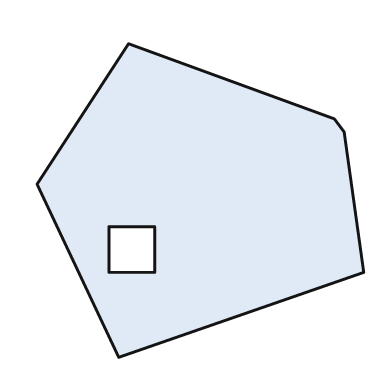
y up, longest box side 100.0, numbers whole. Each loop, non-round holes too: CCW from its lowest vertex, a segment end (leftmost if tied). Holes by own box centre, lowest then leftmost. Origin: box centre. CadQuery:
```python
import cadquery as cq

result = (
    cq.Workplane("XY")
    .moveTo(-25.0, -48.0)
    .lineTo(50.0, -22.0)
    .lineTo(44.0, 21.0)
    .lineTo(41.0, 25.0)
    .lineTo(-22.0, 48.0)
    .lineTo(-50.0, 5.0)
    .close()
    .moveTo(-28.0, -22.0)
    .lineTo(-14.0, -22.0)
    .lineTo(-14.0, -8.0)
    .lineTo(-28.0, -8.0)
    .close()
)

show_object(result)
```